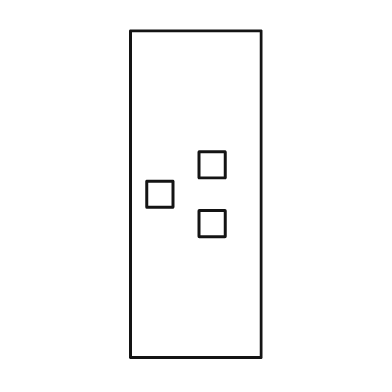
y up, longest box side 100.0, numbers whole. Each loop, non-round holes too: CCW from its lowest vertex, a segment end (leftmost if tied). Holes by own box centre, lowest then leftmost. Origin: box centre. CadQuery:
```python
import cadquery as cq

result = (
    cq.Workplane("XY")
    .moveTo(-20.0, -50.0)
    .lineTo(20.0, -50.0)
    .lineTo(20.0, 50.0)
    .lineTo(-20.0, 50.0)
    .close()
    .moveTo(1.0, -13.0)
    .lineTo(9.0, -13.0)
    .lineTo(9.0, -5.0)
    .lineTo(1.0, -5.0)
    .close()
    .moveTo(-15.0, -4.0)
    .lineTo(-7.0, -4.0)
    .lineTo(-7.0, 4.0)
    .lineTo(-15.0, 4.0)
    .close()
    .moveTo(1.0, 5.0)
    .lineTo(9.0, 5.0)
    .lineTo(9.0, 13.0)
    .lineTo(1.0, 13.0)
    .close()
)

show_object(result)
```